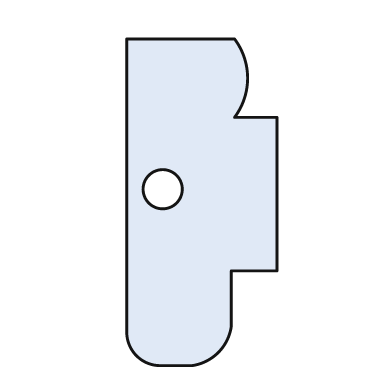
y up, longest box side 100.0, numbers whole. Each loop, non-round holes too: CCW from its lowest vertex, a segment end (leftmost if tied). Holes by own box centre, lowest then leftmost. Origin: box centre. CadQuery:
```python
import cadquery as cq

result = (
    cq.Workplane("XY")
    .moveTo(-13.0, -50.0)
    .lineTo(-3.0, -50.0)
    .threePointArc((5.0, -46.0), (9.0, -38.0))
    .lineTo(9.0, -21.0)
    .lineTo(23.0, -21.0)
    .lineTo(23.0, 26.0)
    .lineTo(10.0, 26.0)
    .threePointArc((14.0, 38.0), (10.0, 50.0))
    .lineTo(-23.0, 50.0)
    .lineTo(-23.0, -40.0)
    .threePointArc((-20.0, -47.0), (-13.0, -50.0))
    .close()
    .moveTo(-12.0, 4.0)
    .circle(6.0)
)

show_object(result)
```